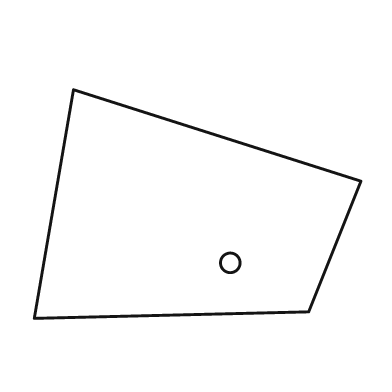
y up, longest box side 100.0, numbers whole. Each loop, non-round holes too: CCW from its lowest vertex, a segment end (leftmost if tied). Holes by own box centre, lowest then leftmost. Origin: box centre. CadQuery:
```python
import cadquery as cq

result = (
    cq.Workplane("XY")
    .moveTo(-50.0, -35.0)
    .lineTo(34.0, -33.0)
    .lineTo(50.0, 7.0)
    .lineTo(-38.0, 35.0)
    .close()
    .moveTo(10.0, -18.0)
    .circle(3.0)
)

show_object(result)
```